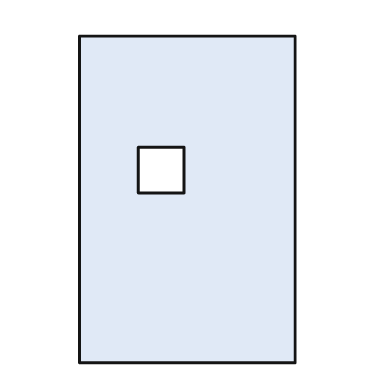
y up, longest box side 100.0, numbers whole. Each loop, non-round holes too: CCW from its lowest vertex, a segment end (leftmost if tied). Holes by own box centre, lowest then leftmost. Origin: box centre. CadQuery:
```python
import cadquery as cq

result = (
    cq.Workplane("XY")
    .moveTo(-33.0, -50.0)
    .lineTo(33.0, -50.0)
    .lineTo(33.0, 50.0)
    .lineTo(-33.0, 50.0)
    .close()
    .moveTo(-15.0, 2.0)
    .lineTo(-1.0, 2.0)
    .lineTo(-1.0, 16.0)
    .lineTo(-15.0, 16.0)
    .close()
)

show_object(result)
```